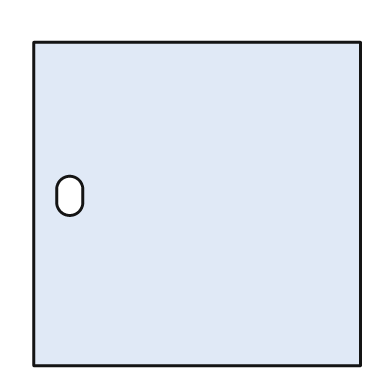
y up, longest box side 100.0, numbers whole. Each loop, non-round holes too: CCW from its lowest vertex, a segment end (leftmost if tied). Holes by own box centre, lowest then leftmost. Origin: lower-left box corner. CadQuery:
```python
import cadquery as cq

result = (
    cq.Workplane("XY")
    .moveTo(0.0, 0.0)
    .lineTo(100.0, 0.0)
    .lineTo(100.0, 99.0)
    .lineTo(0.0, 99.0)
    .close()
    .moveTo(7.0, 50.0)
    .threePointArc((11.0, 46.0), (15.0, 50.0))
    .lineTo(15.0, 54.0)
    .threePointArc((11.0, 58.0), (7.0, 54.0))
    .close()
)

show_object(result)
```